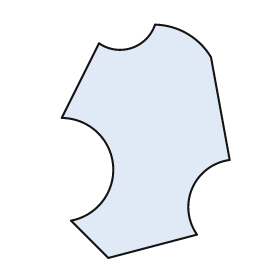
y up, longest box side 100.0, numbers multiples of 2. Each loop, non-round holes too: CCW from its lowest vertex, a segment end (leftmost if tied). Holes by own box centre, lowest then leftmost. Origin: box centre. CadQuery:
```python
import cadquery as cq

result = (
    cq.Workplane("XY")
    .moveTo(-16.0, -50.0)
    .lineTo(22.0, -40.0)
    .threePointArc((20.0, -20.0), (36.0, -8.0))
    .lineTo(28.0, 36.0)
    .threePointArc((18.0, 46.0), (4.0, 50.0))
    .threePointArc((-6.0, 40.0), (-20.0, 42.0))
    .lineTo(-36.0, 10.0)
    .threePointArc((-14.0, -10.0), (-32.0, -34.0))
    .close()
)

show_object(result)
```